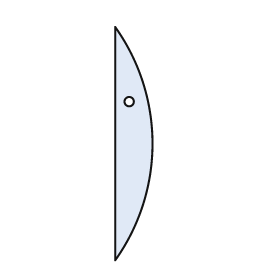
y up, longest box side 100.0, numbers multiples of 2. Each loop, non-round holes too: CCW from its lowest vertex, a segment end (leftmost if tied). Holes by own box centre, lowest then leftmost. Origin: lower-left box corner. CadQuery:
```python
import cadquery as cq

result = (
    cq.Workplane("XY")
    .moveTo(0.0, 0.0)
    .threePointArc((16.0, 50.0), (0.0, 100.0))
    .close()
    .moveTo(6.0, 68.0)
    .circle(2.0)
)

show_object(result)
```